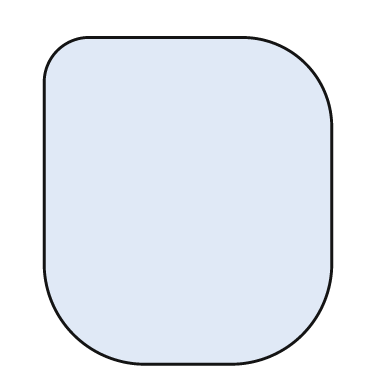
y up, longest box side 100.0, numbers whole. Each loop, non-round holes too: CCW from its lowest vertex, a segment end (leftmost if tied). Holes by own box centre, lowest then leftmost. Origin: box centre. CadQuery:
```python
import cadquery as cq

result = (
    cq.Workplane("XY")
    .moveTo(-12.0, -50.0)
    .lineTo(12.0, -50.0)
    .threePointArc((35.0, -41.0), (44.0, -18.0))
    .lineTo(44.0, 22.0)
    .threePointArc((36.0, 42.0), (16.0, 50.0))
    .lineTo(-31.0, 50.0)
    .threePointArc((-40.0, 46.0), (-44.0, 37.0))
    .lineTo(-44.0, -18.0)
    .threePointArc((-35.0, -41.0), (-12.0, -50.0))
    .close()
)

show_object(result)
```